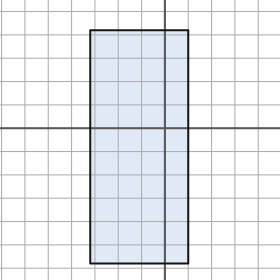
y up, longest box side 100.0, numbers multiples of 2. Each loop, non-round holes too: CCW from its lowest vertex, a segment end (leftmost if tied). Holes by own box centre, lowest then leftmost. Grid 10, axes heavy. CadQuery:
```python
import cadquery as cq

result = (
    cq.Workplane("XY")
    .moveTo(-32.0, -58.0)
    .lineTo(10.0, -58.0)
    .lineTo(10.0, 42.0)
    .lineTo(-32.0, 42.0)
    .close()
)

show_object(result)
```